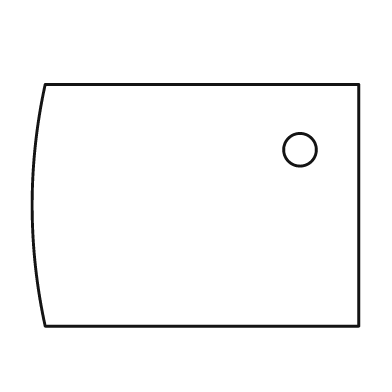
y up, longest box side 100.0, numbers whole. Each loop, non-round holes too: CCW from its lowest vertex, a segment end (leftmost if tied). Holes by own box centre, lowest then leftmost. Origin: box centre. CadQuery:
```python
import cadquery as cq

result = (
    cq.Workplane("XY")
    .moveTo(-46.0, -37.0)
    .lineTo(50.0, -37.0)
    .lineTo(50.0, 37.0)
    .lineTo(-46.0, 37.0)
    .threePointArc((-50.0, 0.0), (-46.0, -37.0))
    .close()
    .moveTo(32.0, 17.0)
    .circle(5.0)
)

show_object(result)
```